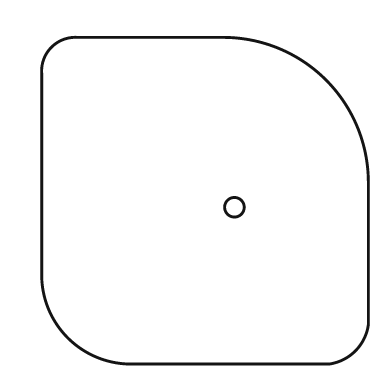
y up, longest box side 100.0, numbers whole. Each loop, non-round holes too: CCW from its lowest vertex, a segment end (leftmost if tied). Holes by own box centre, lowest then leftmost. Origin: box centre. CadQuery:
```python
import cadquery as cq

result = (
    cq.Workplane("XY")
    .moveTo(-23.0, -50.0)
    .lineTo(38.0, -50.0)
    .threePointArc((46.0, -46.0), (50.0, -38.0))
    .lineTo(50.0, 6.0)
    .threePointArc((37.0, 37.0), (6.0, 50.0))
    .lineTo(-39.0, 50.0)
    .threePointArc((-47.0, 47.0), (-50.0, 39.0))
    .lineTo(-50.0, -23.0)
    .threePointArc((-42.0, -42.0), (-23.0, -50.0))
    .close()
    .moveTo(9.0, -2.0)
    .circle(3.0)
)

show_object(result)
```